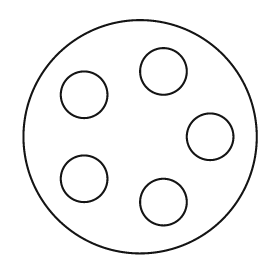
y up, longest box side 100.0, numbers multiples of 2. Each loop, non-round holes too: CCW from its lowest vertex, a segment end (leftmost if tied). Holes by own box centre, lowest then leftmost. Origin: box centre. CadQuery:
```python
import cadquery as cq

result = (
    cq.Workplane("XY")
    .moveTo(0.0, 0.0)
    .circle(50.0)
    .moveTo(10.0, -28.0)
    .circle(10.0)
    .moveTo(-24.0, -18.0)
    .circle(10.0)
    .moveTo(30.0, 0.0)
    .circle(10.0)
    .moveTo(-24.0, 18.0)
    .circle(10.0)
    .moveTo(10.0, 28.0)
    .circle(10.0)
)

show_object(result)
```